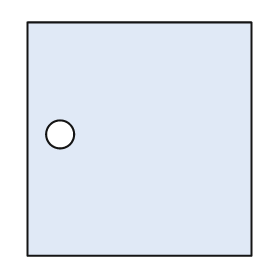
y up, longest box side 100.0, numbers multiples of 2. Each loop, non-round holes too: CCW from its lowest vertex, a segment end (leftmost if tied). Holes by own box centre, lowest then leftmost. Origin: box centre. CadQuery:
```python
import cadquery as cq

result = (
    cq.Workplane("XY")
    .moveTo(-48.0, -50.0)
    .lineTo(48.0, -50.0)
    .lineTo(48.0, 50.0)
    .lineTo(-48.0, 50.0)
    .close()
    .moveTo(-34.0, 2.0)
    .circle(6.0)
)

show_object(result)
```